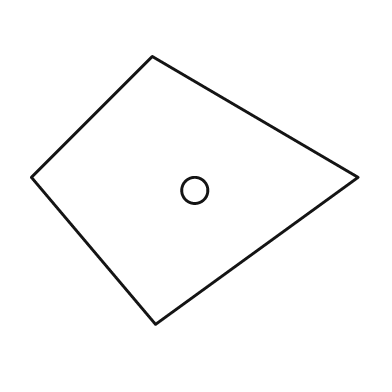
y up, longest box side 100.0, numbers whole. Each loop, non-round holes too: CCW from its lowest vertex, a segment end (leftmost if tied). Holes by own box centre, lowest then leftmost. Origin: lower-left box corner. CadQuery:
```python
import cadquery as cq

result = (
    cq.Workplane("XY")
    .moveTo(38.0, 0.0)
    .lineTo(100.0, 45.0)
    .lineTo(37.0, 82.0)
    .lineTo(0.0, 45.0)
    .close()
    .moveTo(50.0, 41.0)
    .circle(4.0)
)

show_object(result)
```